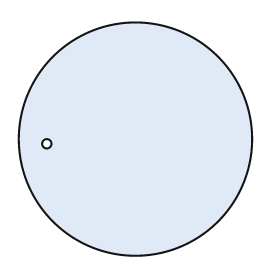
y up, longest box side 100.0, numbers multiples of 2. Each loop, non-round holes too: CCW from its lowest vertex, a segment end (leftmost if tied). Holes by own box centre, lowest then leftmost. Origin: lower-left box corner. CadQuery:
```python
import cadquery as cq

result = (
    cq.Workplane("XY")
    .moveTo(50.0, 50.0)
    .circle(50.0)
    .moveTo(12.0, 48.0)
    .circle(2.0)
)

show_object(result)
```